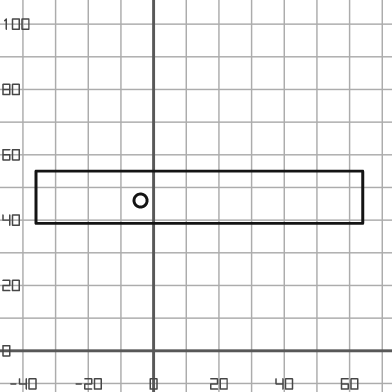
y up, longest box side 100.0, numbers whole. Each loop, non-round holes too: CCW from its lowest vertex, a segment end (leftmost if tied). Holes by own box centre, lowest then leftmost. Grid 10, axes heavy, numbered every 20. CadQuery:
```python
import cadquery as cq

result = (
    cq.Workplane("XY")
    .moveTo(-36.0, 39.0)
    .lineTo(64.0, 39.0)
    .lineTo(64.0, 55.0)
    .lineTo(-36.0, 55.0)
    .close()
    .moveTo(-4.0, 46.0)
    .circle(2.0)
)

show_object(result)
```